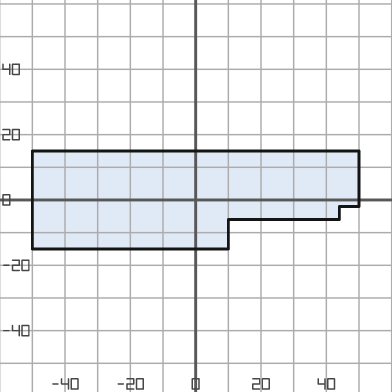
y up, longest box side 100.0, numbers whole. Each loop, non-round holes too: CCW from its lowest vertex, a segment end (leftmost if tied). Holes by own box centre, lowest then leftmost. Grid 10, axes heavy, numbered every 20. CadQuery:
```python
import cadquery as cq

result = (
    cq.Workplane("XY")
    .moveTo(-50.0, -15.0)
    .lineTo(10.0, -15.0)
    .lineTo(10.0, -6.0)
    .lineTo(44.0, -6.0)
    .lineTo(44.0, -2.0)
    .lineTo(50.0, -2.0)
    .lineTo(50.0, 15.0)
    .lineTo(-50.0, 15.0)
    .close()
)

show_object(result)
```